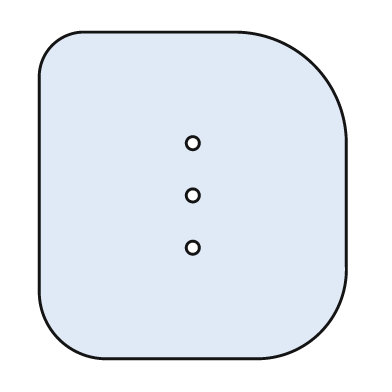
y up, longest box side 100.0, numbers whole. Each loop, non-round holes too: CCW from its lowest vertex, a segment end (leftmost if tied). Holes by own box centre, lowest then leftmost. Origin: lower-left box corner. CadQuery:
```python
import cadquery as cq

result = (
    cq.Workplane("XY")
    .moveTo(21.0, 0.0)
    .lineTo(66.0, 0.0)
    .threePointArc((86.0, 8.0), (94.0, 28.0))
    .lineTo(94.0, 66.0)
    .threePointArc((84.0, 90.0), (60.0, 100.0))
    .lineTo(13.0, 100.0)
    .threePointArc((4.0, 96.0), (0.0, 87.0))
    .lineTo(0.0, 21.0)
    .threePointArc((6.0, 6.0), (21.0, 0.0))
    .close()
    .moveTo(47.0, 34.0)
    .circle(2.0)
    .moveTo(47.0, 50.0)
    .circle(2.0)
    .moveTo(47.0, 66.0)
    .circle(2.0)
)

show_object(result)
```